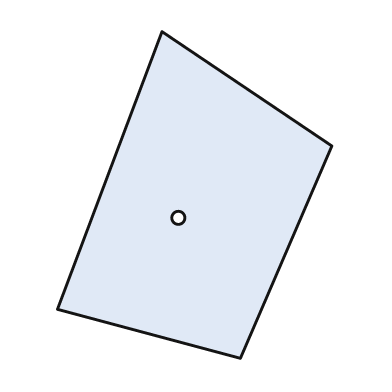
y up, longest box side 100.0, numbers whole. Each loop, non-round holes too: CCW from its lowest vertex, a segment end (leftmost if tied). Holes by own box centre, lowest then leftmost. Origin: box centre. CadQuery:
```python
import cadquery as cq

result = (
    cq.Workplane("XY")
    .moveTo(14.0, -50.0)
    .lineTo(42.0, 15.0)
    .lineTo(-10.0, 50.0)
    .lineTo(-42.0, -35.0)
    .close()
    .moveTo(-5.0, -7.0)
    .circle(2.0)
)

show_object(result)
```